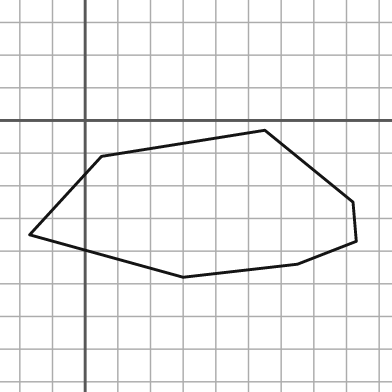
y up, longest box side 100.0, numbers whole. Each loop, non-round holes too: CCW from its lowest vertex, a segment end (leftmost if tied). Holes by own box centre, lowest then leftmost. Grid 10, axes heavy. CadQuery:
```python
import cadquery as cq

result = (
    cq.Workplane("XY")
    .moveTo(30.0, -48.0)
    .lineTo(65.0, -44.0)
    .lineTo(83.0, -37.0)
    .lineTo(82.0, -25.0)
    .lineTo(55.0, -3.0)
    .lineTo(5.0, -11.0)
    .lineTo(-17.0, -35.0)
    .close()
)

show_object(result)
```